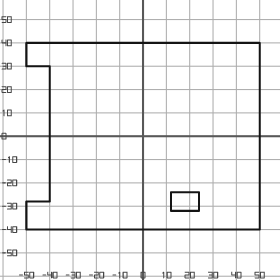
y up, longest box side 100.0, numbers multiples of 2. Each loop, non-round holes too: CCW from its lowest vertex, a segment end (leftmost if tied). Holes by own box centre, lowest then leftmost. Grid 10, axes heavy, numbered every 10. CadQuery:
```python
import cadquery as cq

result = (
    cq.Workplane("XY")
    .moveTo(-50.0, -40.0)
    .lineTo(50.0, -40.0)
    .lineTo(50.0, 40.0)
    .lineTo(-50.0, 40.0)
    .lineTo(-50.0, 30.0)
    .lineTo(-40.0, 30.0)
    .lineTo(-40.0, -28.0)
    .lineTo(-50.0, -28.0)
    .close()
    .moveTo(12.0, -32.0)
    .lineTo(24.0, -32.0)
    .lineTo(24.0, -24.0)
    .lineTo(12.0, -24.0)
    .close()
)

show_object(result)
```